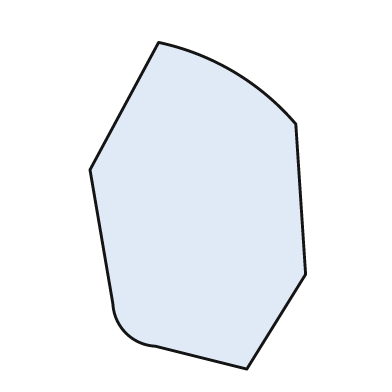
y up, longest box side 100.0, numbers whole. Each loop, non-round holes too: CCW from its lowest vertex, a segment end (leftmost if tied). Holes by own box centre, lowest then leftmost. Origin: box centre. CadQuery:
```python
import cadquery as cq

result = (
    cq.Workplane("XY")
    .moveTo(15.0, -50.0)
    .lineTo(33.0, -21.0)
    .lineTo(30.0, 25.0)
    .threePointArc((11.0, 41.0), (-12.0, 50.0))
    .lineTo(-33.0, 11.0)
    .lineTo(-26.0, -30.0)
    .threePointArc((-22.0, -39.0), (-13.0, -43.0))
    .close()
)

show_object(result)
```